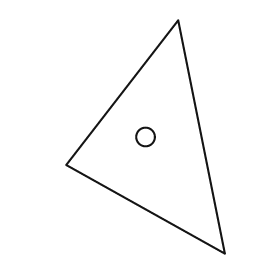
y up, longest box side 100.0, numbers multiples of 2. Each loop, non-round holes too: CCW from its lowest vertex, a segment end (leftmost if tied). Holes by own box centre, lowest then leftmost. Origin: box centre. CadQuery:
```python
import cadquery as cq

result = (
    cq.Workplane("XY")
    .moveTo(34.0, -50.0)
    .lineTo(14.0, 50.0)
    .lineTo(-34.0, -12.0)
    .close()
    .moveTo(0.0, 0.0)
    .circle(4.0)
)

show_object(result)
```